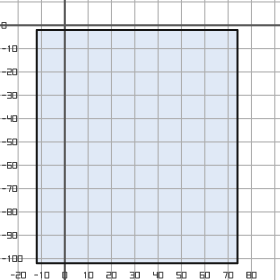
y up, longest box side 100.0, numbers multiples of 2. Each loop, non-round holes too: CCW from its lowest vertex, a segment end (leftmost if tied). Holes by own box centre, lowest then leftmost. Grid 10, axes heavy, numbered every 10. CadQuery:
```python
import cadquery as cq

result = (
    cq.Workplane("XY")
    .moveTo(-12.0, -102.0)
    .lineTo(74.0, -102.0)
    .lineTo(74.0, -2.0)
    .lineTo(-12.0, -2.0)
    .close()
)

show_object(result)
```